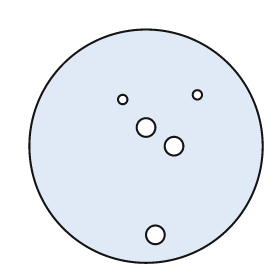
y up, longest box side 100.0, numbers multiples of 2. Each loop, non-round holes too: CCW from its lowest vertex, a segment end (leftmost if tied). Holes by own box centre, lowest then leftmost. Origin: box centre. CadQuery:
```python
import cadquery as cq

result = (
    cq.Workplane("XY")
    .moveTo(0.0, 0.0)
    .circle(50.0)
    .moveTo(4.0, -38.0)
    .circle(4.0)
    .moveTo(12.0, 0.0)
    .circle(4.0)
    .moveTo(0.0, 8.0)
    .circle(4.0)
    .moveTo(-10.0, 20.0)
    .circle(2.0)
    .moveTo(22.0, 22.0)
    .circle(2.0)
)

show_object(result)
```